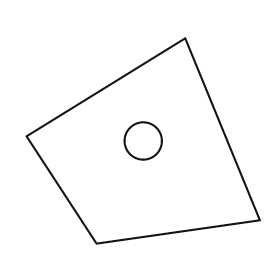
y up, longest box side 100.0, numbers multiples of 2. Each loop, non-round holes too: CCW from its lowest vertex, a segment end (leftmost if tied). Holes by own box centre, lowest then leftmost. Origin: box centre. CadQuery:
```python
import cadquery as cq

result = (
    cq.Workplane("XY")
    .moveTo(-20.0, -44.0)
    .lineTo(50.0, -34.0)
    .lineTo(18.0, 44.0)
    .lineTo(-50.0, 2.0)
    .close()
    .moveTo(0.0, 0.0)
    .circle(8.0)
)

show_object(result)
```